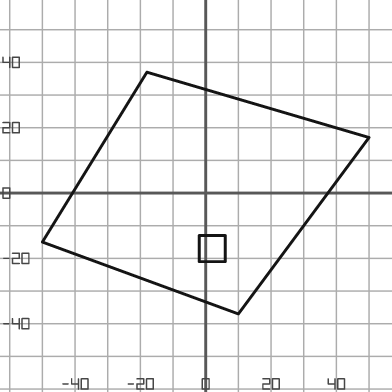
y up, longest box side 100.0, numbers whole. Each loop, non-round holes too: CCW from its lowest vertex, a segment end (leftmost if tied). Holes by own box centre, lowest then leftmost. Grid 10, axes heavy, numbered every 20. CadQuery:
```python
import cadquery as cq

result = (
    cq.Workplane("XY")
    .moveTo(10.0, -37.0)
    .lineTo(50.0, 17.0)
    .lineTo(-18.0, 37.0)
    .lineTo(-50.0, -15.0)
    .close()
    .moveTo(-2.0, -21.0)
    .lineTo(6.0, -21.0)
    .lineTo(6.0, -13.0)
    .lineTo(-2.0, -13.0)
    .close()
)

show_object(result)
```